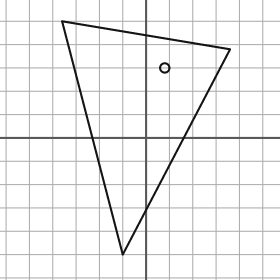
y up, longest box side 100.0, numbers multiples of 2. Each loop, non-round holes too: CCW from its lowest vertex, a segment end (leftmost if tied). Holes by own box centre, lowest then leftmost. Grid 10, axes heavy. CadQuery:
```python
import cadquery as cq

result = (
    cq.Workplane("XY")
    .moveTo(-10.0, -50.0)
    .lineTo(36.0, 38.0)
    .lineTo(-36.0, 50.0)
    .close()
    .moveTo(8.0, 30.0)
    .circle(2.0)
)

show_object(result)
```